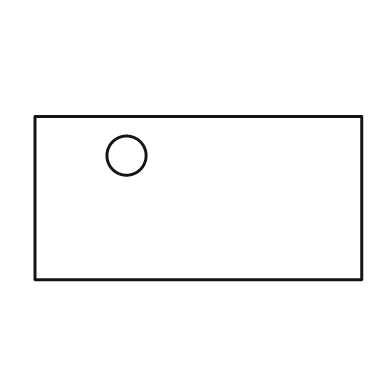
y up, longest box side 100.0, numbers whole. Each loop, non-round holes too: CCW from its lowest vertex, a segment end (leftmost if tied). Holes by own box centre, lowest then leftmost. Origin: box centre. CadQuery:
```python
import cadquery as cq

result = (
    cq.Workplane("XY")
    .moveTo(-50.0, -25.0)
    .lineTo(50.0, -25.0)
    .lineTo(50.0, 25.0)
    .lineTo(-50.0, 25.0)
    .close()
    .moveTo(-22.0, 13.0)
    .circle(6.0)
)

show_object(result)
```